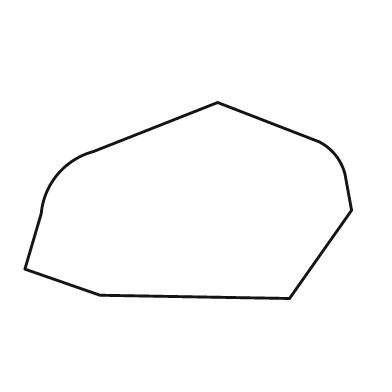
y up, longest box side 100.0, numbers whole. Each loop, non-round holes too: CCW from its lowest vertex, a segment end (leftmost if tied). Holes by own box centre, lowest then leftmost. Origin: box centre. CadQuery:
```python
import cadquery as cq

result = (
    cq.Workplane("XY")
    .moveTo(31.0, -30.0)
    .lineTo(50.0, -3.0)
    .lineTo(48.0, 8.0)
    .threePointArc((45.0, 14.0), (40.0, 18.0))
    .lineTo(9.0, 30.0)
    .lineTo(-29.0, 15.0)
    .threePointArc((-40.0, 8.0), (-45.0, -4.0))
    .lineTo(-50.0, -21.0)
    .lineTo(-27.0, -29.0)
    .close()
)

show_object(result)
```